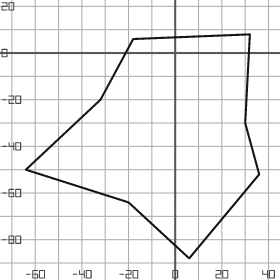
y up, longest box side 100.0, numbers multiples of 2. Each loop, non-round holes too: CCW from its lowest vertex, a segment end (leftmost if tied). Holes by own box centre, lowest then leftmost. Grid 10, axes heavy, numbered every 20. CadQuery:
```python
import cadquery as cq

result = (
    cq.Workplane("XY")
    .moveTo(6.0, -88.0)
    .lineTo(36.0, -52.0)
    .lineTo(30.0, -30.0)
    .lineTo(32.0, 8.0)
    .lineTo(-18.0, 6.0)
    .lineTo(-32.0, -20.0)
    .lineTo(-64.0, -50.0)
    .lineTo(-20.0, -64.0)
    .close()
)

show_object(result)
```